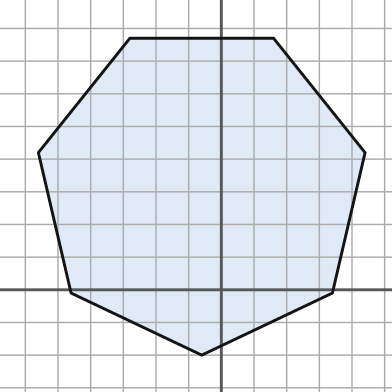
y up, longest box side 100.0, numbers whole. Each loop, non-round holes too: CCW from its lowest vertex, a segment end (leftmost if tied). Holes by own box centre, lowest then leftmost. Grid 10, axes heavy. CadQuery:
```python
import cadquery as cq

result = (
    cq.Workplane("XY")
    .moveTo(-6.0, -20.0)
    .lineTo(34.0, -1.0)
    .lineTo(44.0, 42.0)
    .lineTo(16.0, 77.0)
    .lineTo(-28.0, 77.0)
    .lineTo(-56.0, 42.0)
    .lineTo(-46.0, -1.0)
    .close()
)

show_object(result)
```